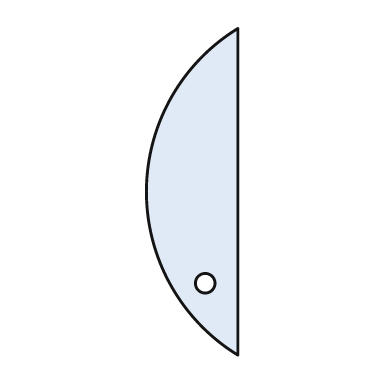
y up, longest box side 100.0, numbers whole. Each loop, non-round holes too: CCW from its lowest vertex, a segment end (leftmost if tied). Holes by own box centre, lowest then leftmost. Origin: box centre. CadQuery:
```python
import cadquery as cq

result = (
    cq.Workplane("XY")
    .moveTo(14.0, -50.0)
    .lineTo(14.0, 50.0)
    .threePointArc((-14.0, 0.0), (14.0, -50.0))
    .close()
    .moveTo(4.0, -28.0)
    .circle(3.0)
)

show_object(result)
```